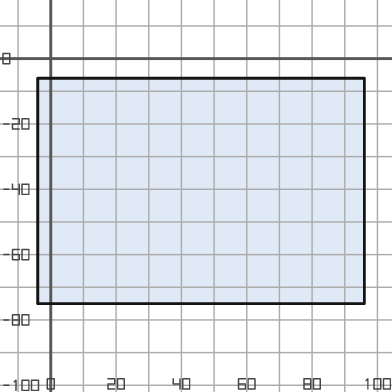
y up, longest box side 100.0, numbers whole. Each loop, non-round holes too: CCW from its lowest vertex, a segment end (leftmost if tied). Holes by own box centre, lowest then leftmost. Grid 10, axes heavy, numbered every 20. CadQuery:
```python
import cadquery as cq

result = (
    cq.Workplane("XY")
    .moveTo(-4.0, -75.0)
    .lineTo(96.0, -75.0)
    .lineTo(96.0, -6.0)
    .lineTo(-4.0, -6.0)
    .close()
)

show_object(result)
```